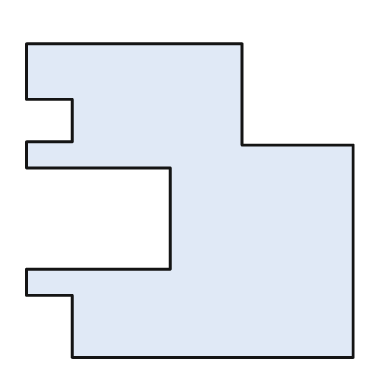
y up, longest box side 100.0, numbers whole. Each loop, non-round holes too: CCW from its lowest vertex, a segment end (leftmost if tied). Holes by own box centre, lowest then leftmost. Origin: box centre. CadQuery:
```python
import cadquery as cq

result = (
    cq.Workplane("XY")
    .moveTo(-36.0, -48.0)
    .lineTo(50.0, -48.0)
    .lineTo(50.0, 17.0)
    .lineTo(16.0, 17.0)
    .lineTo(16.0, 48.0)
    .lineTo(-50.0, 48.0)
    .lineTo(-50.0, 31.0)
    .lineTo(-36.0, 31.0)
    .lineTo(-36.0, 18.0)
    .lineTo(-50.0, 18.0)
    .lineTo(-50.0, 10.0)
    .lineTo(-6.0, 10.0)
    .lineTo(-6.0, -21.0)
    .lineTo(-50.0, -21.0)
    .lineTo(-50.0, -29.0)
    .lineTo(-36.0, -29.0)
    .close()
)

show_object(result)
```